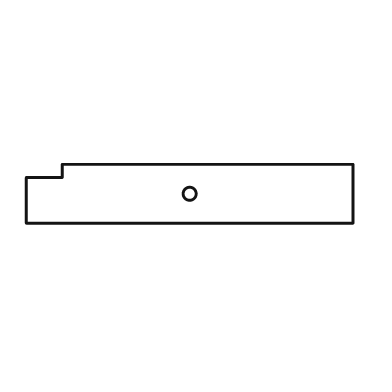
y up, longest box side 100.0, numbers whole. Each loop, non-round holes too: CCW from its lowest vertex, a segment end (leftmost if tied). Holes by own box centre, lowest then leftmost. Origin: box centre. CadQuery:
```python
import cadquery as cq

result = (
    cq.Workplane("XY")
    .moveTo(-50.0, -9.0)
    .lineTo(50.0, -9.0)
    .lineTo(50.0, 9.0)
    .lineTo(-39.0, 9.0)
    .lineTo(-39.0, 5.0)
    .lineTo(-50.0, 5.0)
    .close()
    .moveTo(0.0, 0.0)
    .circle(2.0)
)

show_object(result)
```